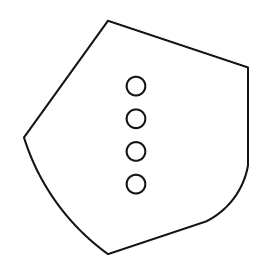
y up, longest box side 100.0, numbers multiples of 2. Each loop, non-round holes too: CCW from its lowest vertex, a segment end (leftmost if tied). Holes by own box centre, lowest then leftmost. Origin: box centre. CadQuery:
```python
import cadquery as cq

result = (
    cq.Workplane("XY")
    .moveTo(-12.0, -50.0)
    .lineTo(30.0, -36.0)
    .threePointArc((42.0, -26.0), (48.0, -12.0))
    .lineTo(48.0, 30.0)
    .lineTo(-12.0, 50.0)
    .lineTo(-48.0, 0.0)
    .threePointArc((-34.0, -28.0), (-12.0, -50.0))
    .close()
    .moveTo(0.0, -20.0)
    .circle(4.0)
    .moveTo(0.0, -6.0)
    .circle(4.0)
    .moveTo(0.0, 8.0)
    .circle(4.0)
    .moveTo(0.0, 22.0)
    .circle(4.0)
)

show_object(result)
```